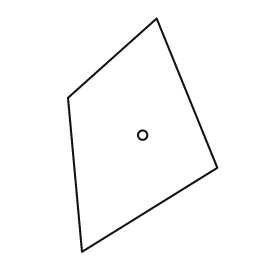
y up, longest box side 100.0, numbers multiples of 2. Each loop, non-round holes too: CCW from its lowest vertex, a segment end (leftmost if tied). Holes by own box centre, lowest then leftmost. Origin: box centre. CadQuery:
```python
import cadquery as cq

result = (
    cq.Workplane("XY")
    .moveTo(-26.0, -50.0)
    .lineTo(32.0, -14.0)
    .lineTo(6.0, 50.0)
    .lineTo(-32.0, 16.0)
    .close()
    .moveTo(0.0, 0.0)
    .circle(2.0)
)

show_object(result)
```